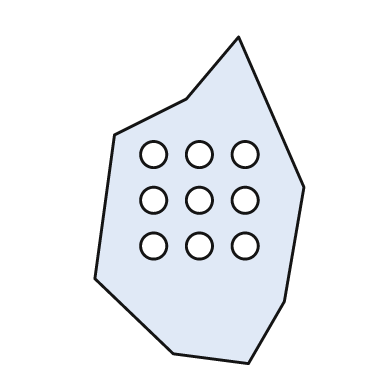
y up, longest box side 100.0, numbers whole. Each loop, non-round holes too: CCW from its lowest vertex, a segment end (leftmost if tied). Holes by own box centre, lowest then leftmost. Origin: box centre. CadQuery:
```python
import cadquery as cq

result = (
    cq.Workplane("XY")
    .moveTo(15.0, -50.0)
    .lineTo(26.0, -31.0)
    .lineTo(32.0, 4.0)
    .lineTo(12.0, 50.0)
    .lineTo(-4.0, 31.0)
    .lineTo(-26.0, 20.0)
    .lineTo(-32.0, -24.0)
    .lineTo(-8.0, -47.0)
    .close()
    .moveTo(-14.0, -14.0)
    .circle(4.0)
    .moveTo(0.0, -14.0)
    .circle(4.0)
    .moveTo(14.0, -14.0)
    .circle(4.0)
    .moveTo(-14.0, 0.0)
    .circle(4.0)
    .moveTo(0.0, 0.0)
    .circle(4.0)
    .moveTo(14.0, 0.0)
    .circle(4.0)
    .moveTo(-14.0, 14.0)
    .circle(4.0)
    .moveTo(0.0, 14.0)
    .circle(4.0)
    .moveTo(14.0, 14.0)
    .circle(4.0)
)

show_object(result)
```